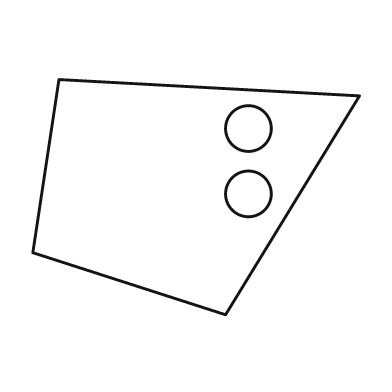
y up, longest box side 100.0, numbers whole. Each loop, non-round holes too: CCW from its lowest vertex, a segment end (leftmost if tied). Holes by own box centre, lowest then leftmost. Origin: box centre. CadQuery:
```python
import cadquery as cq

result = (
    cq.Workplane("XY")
    .moveTo(9.0, -36.0)
    .lineTo(50.0, 31.0)
    .lineTo(-42.0, 36.0)
    .lineTo(-50.0, -17.0)
    .close()
    .moveTo(16.0, 1.0)
    .circle(7.0)
    .moveTo(16.0, 21.0)
    .circle(7.0)
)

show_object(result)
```